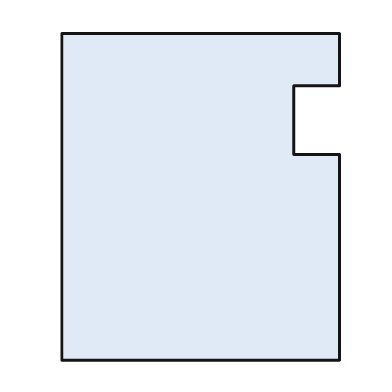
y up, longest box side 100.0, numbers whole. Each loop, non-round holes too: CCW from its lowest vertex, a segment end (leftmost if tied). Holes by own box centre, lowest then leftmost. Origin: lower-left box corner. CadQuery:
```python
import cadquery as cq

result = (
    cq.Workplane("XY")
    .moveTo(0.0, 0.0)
    .lineTo(85.0, 0.0)
    .lineTo(85.0, 63.0)
    .lineTo(71.0, 63.0)
    .lineTo(71.0, 84.0)
    .lineTo(85.0, 84.0)
    .lineTo(85.0, 100.0)
    .lineTo(0.0, 100.0)
    .close()
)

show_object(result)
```